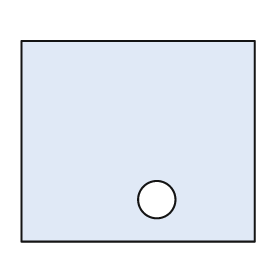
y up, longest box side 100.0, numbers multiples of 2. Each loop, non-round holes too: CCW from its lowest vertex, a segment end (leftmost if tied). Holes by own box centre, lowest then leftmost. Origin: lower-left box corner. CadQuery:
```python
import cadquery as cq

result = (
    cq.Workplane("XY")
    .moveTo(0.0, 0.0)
    .lineTo(100.0, 0.0)
    .lineTo(100.0, 86.0)
    .lineTo(0.0, 86.0)
    .close()
    .moveTo(58.0, 18.0)
    .circle(8.0)
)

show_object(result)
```